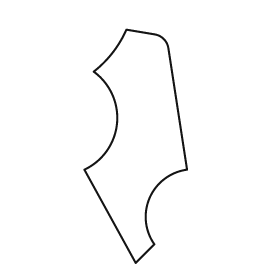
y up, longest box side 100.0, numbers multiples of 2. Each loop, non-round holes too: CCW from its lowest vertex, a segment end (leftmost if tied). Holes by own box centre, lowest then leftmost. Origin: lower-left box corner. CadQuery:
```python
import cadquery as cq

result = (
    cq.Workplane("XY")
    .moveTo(22.0, 0.0)
    .lineTo(30.0, 8.0)
    .threePointArc((28.0, 28.0), (44.0, 40.0))
    .lineTo(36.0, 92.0)
    .threePointArc((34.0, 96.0), (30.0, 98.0))
    .lineTo(18.0, 100.0)
    .threePointArc((12.0, 90.0), (4.0, 82.0))
    .threePointArc((14.0, 60.0), (0.0, 40.0))
    .close()
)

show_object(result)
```